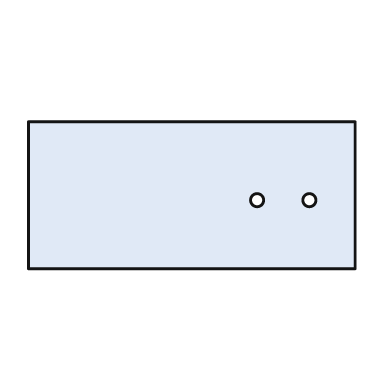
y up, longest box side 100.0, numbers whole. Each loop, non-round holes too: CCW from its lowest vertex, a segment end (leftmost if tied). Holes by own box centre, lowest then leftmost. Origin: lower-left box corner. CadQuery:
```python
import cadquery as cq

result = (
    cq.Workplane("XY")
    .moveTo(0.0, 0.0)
    .lineTo(100.0, 0.0)
    .lineTo(100.0, 45.0)
    .lineTo(0.0, 45.0)
    .close()
    .moveTo(70.0, 21.0)
    .circle(2.0)
    .moveTo(86.0, 21.0)
    .circle(2.0)
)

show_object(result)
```